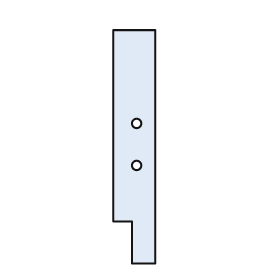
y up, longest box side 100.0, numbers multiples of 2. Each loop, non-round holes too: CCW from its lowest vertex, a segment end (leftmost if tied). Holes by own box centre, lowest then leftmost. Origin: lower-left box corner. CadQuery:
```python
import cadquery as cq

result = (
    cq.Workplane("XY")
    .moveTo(8.0, 0.0)
    .lineTo(18.0, 0.0)
    .lineTo(18.0, 100.0)
    .lineTo(0.0, 100.0)
    .lineTo(0.0, 18.0)
    .lineTo(8.0, 18.0)
    .close()
    .moveTo(10.0, 42.0)
    .circle(2.0)
    .moveTo(10.0, 60.0)
    .circle(2.0)
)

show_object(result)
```